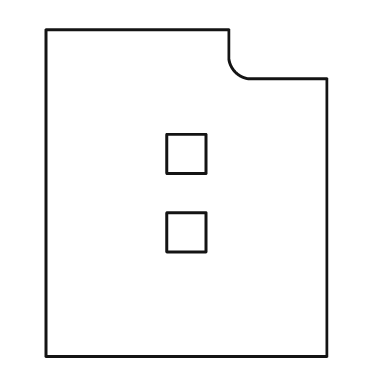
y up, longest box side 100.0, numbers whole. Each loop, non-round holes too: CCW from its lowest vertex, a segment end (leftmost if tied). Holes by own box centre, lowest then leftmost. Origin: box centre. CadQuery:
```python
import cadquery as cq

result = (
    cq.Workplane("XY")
    .moveTo(-43.0, -50.0)
    .lineTo(43.0, -50.0)
    .lineTo(43.0, 35.0)
    .lineTo(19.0, 35.0)
    .threePointArc((15.0, 37.0), (13.0, 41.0))
    .lineTo(13.0, 50.0)
    .lineTo(-43.0, 50.0)
    .close()
    .moveTo(-6.0, -18.0)
    .lineTo(6.0, -18.0)
    .lineTo(6.0, -6.0)
    .lineTo(-6.0, -6.0)
    .close()
    .moveTo(-6.0, 6.0)
    .lineTo(6.0, 6.0)
    .lineTo(6.0, 18.0)
    .lineTo(-6.0, 18.0)
    .close()
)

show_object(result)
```